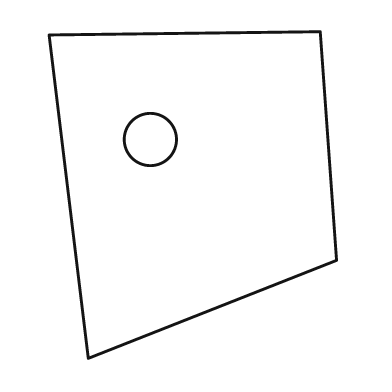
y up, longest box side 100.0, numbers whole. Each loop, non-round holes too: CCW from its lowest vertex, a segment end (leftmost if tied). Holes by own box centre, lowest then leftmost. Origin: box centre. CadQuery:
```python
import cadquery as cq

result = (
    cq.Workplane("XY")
    .moveTo(-32.0, -50.0)
    .lineTo(44.0, -20.0)
    .lineTo(39.0, 50.0)
    .lineTo(-44.0, 49.0)
    .close()
    .moveTo(-13.0, 17.0)
    .circle(8.0)
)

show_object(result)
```